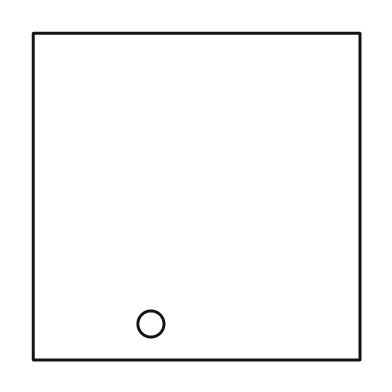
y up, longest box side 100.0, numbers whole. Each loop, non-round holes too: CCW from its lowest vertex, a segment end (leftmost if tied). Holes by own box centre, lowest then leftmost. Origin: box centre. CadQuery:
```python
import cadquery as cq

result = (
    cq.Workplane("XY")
    .moveTo(-50.0, -50.0)
    .lineTo(50.0, -50.0)
    .lineTo(50.0, 50.0)
    .lineTo(-50.0, 50.0)
    .close()
    .moveTo(-14.0, -39.0)
    .circle(4.0)
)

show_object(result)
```